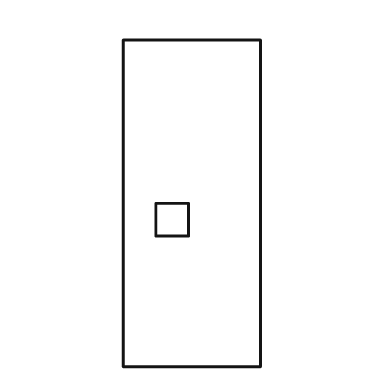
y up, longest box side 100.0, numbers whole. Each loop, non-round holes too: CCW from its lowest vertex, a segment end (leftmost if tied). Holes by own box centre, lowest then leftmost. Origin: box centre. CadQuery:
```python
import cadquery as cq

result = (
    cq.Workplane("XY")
    .moveTo(-21.0, -50.0)
    .lineTo(21.0, -50.0)
    .lineTo(21.0, 50.0)
    .lineTo(-21.0, 50.0)
    .close()
    .moveTo(-11.0, -10.0)
    .lineTo(-1.0, -10.0)
    .lineTo(-1.0, 0.0)
    .lineTo(-11.0, 0.0)
    .close()
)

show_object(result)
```